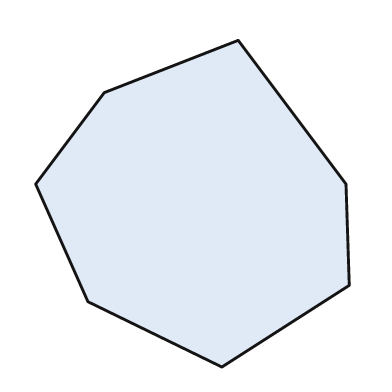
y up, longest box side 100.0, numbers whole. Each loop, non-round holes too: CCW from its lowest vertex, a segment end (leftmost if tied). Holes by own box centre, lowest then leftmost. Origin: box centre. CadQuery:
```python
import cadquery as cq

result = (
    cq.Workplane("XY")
    .moveTo(9.0, -50.0)
    .lineTo(48.0, -25.0)
    .lineTo(47.0, 6.0)
    .lineTo(14.0, 50.0)
    .lineTo(-27.0, 34.0)
    .lineTo(-48.0, 6.0)
    .lineTo(-32.0, -30.0)
    .close()
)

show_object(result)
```